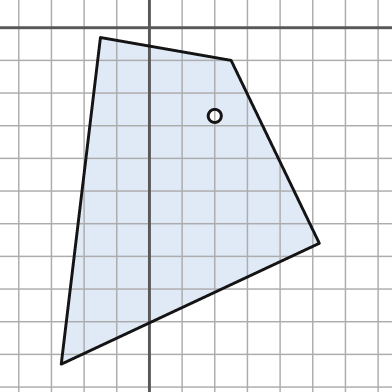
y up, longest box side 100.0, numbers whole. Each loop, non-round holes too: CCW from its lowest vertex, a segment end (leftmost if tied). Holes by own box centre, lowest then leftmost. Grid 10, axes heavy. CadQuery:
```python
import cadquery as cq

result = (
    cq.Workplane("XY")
    .moveTo(-27.0, -103.0)
    .lineTo(52.0, -66.0)
    .lineTo(25.0, -10.0)
    .lineTo(-15.0, -3.0)
    .close()
    .moveTo(20.0, -27.0)
    .circle(2.0)
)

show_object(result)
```